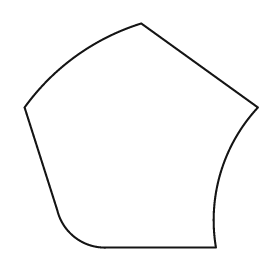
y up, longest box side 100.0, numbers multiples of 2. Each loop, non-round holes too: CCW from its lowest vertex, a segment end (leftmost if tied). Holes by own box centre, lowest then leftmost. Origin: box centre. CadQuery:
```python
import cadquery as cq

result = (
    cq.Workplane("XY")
    .moveTo(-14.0, -48.0)
    .lineTo(32.0, -48.0)
    .threePointArc((34.0, -16.0), (50.0, 12.0))
    .lineTo(0.0, 48.0)
    .threePointArc((-28.0, 34.0), (-50.0, 12.0))
    .lineTo(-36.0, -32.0)
    .threePointArc((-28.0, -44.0), (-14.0, -48.0))
    .close()
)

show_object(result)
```